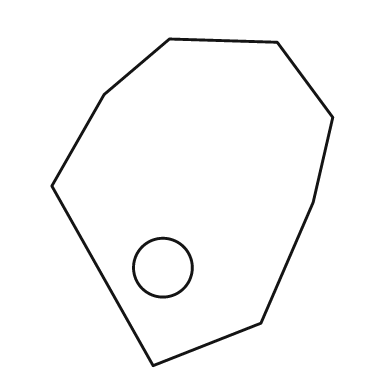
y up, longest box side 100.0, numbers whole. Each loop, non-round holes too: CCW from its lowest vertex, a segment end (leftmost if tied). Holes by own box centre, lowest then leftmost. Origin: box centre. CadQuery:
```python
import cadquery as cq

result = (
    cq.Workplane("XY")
    .moveTo(-12.0, -50.0)
    .lineTo(21.0, -37.0)
    .lineTo(37.0, 0.0)
    .lineTo(43.0, 26.0)
    .lineTo(26.0, 49.0)
    .lineTo(-7.0, 50.0)
    .lineTo(-27.0, 33.0)
    .lineTo(-43.0, 5.0)
    .close()
    .moveTo(-9.0, -20.0)
    .circle(9.0)
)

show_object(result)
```